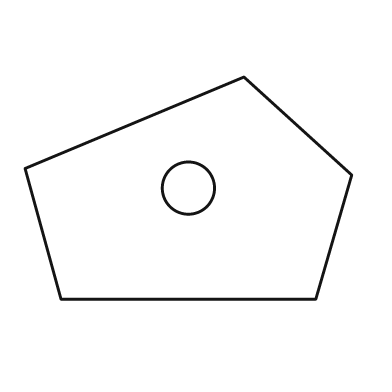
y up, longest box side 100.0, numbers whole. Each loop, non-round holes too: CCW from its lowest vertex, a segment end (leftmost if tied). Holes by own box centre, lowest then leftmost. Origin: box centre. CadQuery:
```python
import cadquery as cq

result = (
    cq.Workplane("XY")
    .moveTo(-39.0, -34.0)
    .lineTo(39.0, -34.0)
    .lineTo(50.0, 4.0)
    .lineTo(17.0, 34.0)
    .lineTo(-50.0, 6.0)
    .close()
    .moveTo(0.0, 0.0)
    .circle(8.0)
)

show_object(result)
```